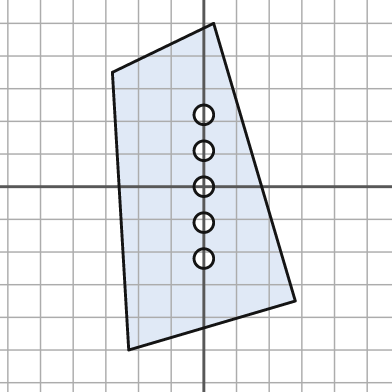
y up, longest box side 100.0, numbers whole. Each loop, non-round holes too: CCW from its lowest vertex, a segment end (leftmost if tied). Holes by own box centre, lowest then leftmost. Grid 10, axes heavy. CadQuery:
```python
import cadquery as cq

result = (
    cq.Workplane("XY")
    .moveTo(-23.0, -50.0)
    .lineTo(28.0, -35.0)
    .lineTo(3.0, 50.0)
    .lineTo(-28.0, 35.0)
    .close()
    .moveTo(0.0, -22.0)
    .circle(3.0)
    .moveTo(0.0, -11.0)
    .circle(3.0)
    .moveTo(0.0, 0.0)
    .circle(3.0)
    .moveTo(0.0, 11.0)
    .circle(3.0)
    .moveTo(0.0, 22.0)
    .circle(3.0)
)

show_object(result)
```